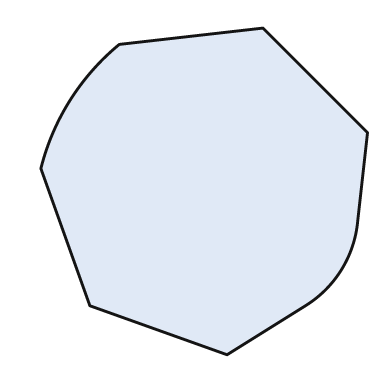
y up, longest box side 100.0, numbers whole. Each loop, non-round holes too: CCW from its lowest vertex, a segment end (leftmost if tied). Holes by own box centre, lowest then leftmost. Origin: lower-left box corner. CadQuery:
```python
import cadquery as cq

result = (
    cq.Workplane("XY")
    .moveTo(57.0, 0.0)
    .lineTo(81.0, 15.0)
    .threePointArc((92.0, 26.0), (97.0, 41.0))
    .lineTo(100.0, 68.0)
    .lineTo(68.0, 100.0)
    .lineTo(24.0, 95.0)
    .threePointArc((9.0, 78.0), (0.0, 57.0))
    .lineTo(15.0, 15.0)
    .close()
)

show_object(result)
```